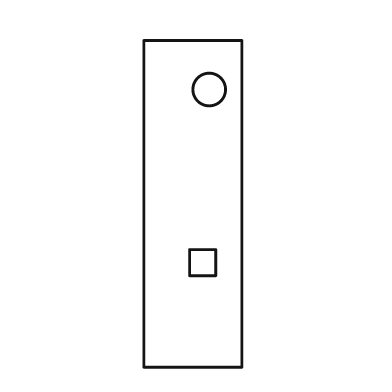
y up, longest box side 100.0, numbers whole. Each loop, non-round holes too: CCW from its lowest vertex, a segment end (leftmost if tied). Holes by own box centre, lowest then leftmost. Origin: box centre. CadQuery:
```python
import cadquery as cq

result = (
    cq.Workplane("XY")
    .moveTo(-15.0, -50.0)
    .lineTo(15.0, -50.0)
    .lineTo(15.0, 50.0)
    .lineTo(-15.0, 50.0)
    .close()
    .moveTo(-1.0, -22.0)
    .lineTo(7.0, -22.0)
    .lineTo(7.0, -14.0)
    .lineTo(-1.0, -14.0)
    .close()
    .moveTo(5.0, 35.0)
    .circle(5.0)
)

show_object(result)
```